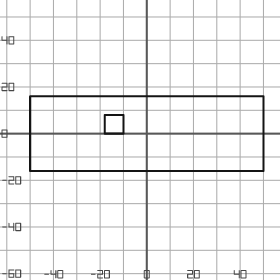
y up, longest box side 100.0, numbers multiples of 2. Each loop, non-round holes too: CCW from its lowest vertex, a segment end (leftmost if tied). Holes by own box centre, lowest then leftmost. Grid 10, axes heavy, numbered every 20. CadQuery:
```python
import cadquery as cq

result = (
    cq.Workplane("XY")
    .moveTo(-50.0, -16.0)
    .lineTo(50.0, -16.0)
    .lineTo(50.0, 16.0)
    .lineTo(-50.0, 16.0)
    .close()
    .moveTo(-18.0, 0.0)
    .lineTo(-10.0, 0.0)
    .lineTo(-10.0, 8.0)
    .lineTo(-18.0, 8.0)
    .close()
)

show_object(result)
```